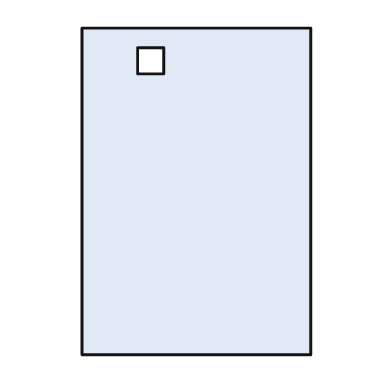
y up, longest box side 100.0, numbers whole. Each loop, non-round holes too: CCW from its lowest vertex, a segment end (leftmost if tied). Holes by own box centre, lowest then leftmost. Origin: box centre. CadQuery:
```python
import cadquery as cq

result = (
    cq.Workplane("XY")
    .moveTo(-35.0, -50.0)
    .lineTo(35.0, -50.0)
    .lineTo(35.0, 50.0)
    .lineTo(-35.0, 50.0)
    .close()
    .moveTo(-18.0, 36.0)
    .lineTo(-10.0, 36.0)
    .lineTo(-10.0, 44.0)
    .lineTo(-18.0, 44.0)
    .close()
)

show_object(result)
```